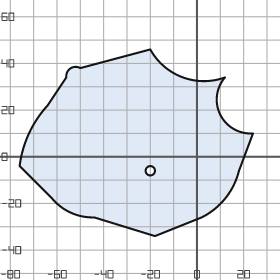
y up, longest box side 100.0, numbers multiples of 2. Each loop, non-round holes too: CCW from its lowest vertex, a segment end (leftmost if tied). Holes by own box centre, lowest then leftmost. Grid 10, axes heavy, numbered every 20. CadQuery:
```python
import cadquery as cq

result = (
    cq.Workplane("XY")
    .moveTo(-18.0, -34.0)
    .lineTo(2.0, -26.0)
    .threePointArc((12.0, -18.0), (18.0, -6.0))
    .lineTo(24.0, 10.0)
    .threePointArc((10.0, 18.0), (12.0, 34.0))
    .threePointArc((-6.0, 34.0), (-20.0, 46.0))
    .lineTo(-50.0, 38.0)
    .threePointArc((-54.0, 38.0), (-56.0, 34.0))
    .lineTo(-64.0, 22.0)
    .threePointArc((-72.0, 10.0), (-76.0, -4.0))
    .lineTo(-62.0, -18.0)
    .threePointArc((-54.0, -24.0), (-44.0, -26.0))
    .close()
    .moveTo(-20.0, -6.0)
    .circle(2.0)
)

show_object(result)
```